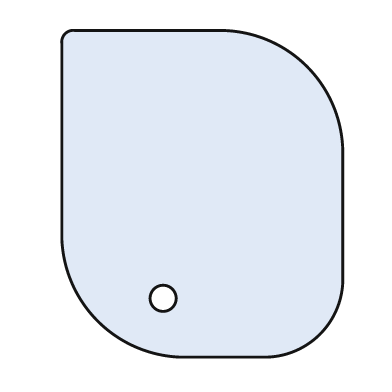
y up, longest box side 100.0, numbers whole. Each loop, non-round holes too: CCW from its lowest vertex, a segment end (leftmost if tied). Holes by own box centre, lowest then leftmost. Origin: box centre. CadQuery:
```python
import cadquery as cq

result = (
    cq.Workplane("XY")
    .moveTo(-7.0, -50.0)
    .lineTo(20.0, -50.0)
    .threePointArc((36.0, -43.0), (43.0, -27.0))
    .lineTo(43.0, 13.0)
    .threePointArc((32.0, 39.0), (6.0, 50.0))
    .lineTo(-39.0, 50.0)
    .threePointArc((-42.0, 49.0), (-43.0, 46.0))
    .lineTo(-43.0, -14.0)
    .threePointArc((-32.0, -39.0), (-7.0, -50.0))
    .close()
    .moveTo(-12.0, -32.0)
    .circle(4.0)
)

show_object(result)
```